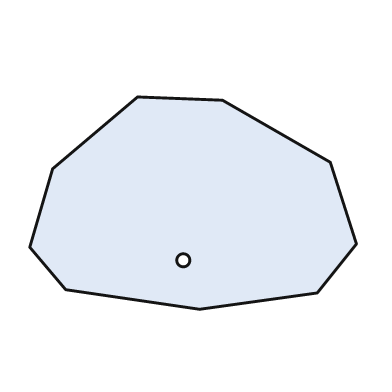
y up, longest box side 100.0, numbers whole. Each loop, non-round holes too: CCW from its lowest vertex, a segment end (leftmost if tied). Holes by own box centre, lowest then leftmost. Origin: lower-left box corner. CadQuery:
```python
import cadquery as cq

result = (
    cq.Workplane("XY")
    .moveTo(52.0, 0.0)
    .lineTo(88.0, 5.0)
    .lineTo(100.0, 20.0)
    .lineTo(92.0, 45.0)
    .lineTo(59.0, 64.0)
    .lineTo(33.0, 65.0)
    .lineTo(7.0, 43.0)
    .lineTo(0.0, 19.0)
    .lineTo(11.0, 6.0)
    .close()
    .moveTo(47.0, 15.0)
    .circle(2.0)
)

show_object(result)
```